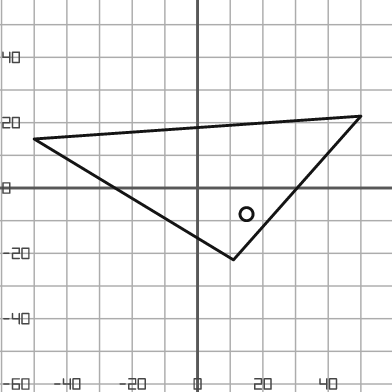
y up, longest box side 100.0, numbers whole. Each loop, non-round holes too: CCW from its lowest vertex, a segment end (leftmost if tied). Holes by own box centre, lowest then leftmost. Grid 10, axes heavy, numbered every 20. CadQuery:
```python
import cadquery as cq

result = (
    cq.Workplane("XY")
    .moveTo(11.0, -22.0)
    .lineTo(50.0, 22.0)
    .lineTo(-50.0, 15.0)
    .close()
    .moveTo(15.0, -8.0)
    .circle(2.0)
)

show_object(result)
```